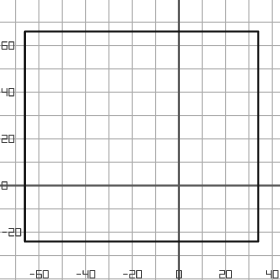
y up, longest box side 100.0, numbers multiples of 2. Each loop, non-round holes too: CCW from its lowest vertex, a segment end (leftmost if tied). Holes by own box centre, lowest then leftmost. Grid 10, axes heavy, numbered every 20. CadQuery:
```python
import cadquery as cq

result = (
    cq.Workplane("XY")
    .moveTo(-66.0, -24.0)
    .lineTo(34.0, -24.0)
    .lineTo(34.0, 66.0)
    .lineTo(-66.0, 66.0)
    .close()
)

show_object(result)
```